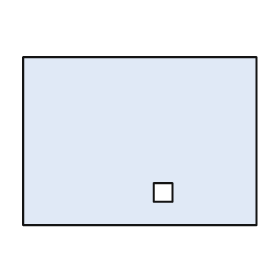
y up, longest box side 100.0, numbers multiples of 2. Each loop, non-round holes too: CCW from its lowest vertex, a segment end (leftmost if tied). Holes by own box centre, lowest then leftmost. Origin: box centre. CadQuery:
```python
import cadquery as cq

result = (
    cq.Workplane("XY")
    .moveTo(-50.0, -36.0)
    .lineTo(50.0, -36.0)
    .lineTo(50.0, 36.0)
    .lineTo(-50.0, 36.0)
    .close()
    .moveTo(6.0, -26.0)
    .lineTo(14.0, -26.0)
    .lineTo(14.0, -18.0)
    .lineTo(6.0, -18.0)
    .close()
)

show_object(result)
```